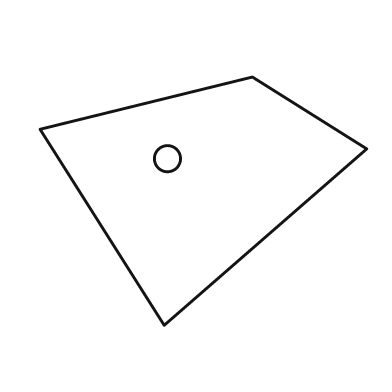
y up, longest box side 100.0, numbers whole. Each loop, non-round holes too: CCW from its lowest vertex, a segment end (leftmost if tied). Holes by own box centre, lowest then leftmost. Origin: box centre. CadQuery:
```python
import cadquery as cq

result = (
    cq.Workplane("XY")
    .moveTo(-12.0, -38.0)
    .lineTo(50.0, 16.0)
    .lineTo(15.0, 38.0)
    .lineTo(-50.0, 22.0)
    .close()
    .moveTo(-11.0, 13.0)
    .circle(4.0)
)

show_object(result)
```